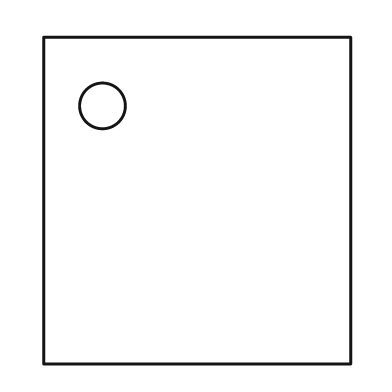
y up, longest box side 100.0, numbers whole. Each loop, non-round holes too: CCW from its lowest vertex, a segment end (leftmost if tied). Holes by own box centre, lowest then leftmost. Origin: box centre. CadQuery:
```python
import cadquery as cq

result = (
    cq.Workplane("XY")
    .moveTo(-47.0, -50.0)
    .lineTo(47.0, -50.0)
    .lineTo(47.0, 50.0)
    .lineTo(-47.0, 50.0)
    .close()
    .moveTo(-29.0, 29.0)
    .circle(7.0)
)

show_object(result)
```